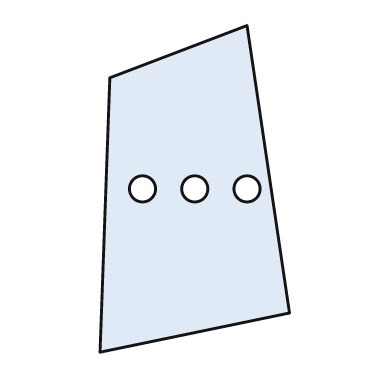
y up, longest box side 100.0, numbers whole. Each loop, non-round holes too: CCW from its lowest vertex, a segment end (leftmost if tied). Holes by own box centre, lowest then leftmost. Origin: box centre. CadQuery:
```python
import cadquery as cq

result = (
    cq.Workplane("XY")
    .moveTo(-29.0, -50.0)
    .lineTo(29.0, -38.0)
    .lineTo(16.0, 50.0)
    .lineTo(-26.0, 34.0)
    .close()
    .moveTo(-16.0, 0.0)
    .circle(4.0)
    .moveTo(0.0, 0.0)
    .circle(4.0)
    .moveTo(16.0, 0.0)
    .circle(4.0)
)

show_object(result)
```